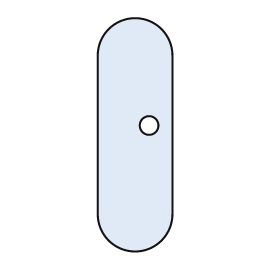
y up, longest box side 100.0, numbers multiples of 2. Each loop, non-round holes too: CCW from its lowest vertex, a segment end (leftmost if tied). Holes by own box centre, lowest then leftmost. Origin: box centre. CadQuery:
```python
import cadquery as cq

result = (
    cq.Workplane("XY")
    .moveTo(-16.0, -34.0)
    .threePointArc((0.0, -50.0), (16.0, -34.0))
    .lineTo(16.0, 34.0)
    .threePointArc((0.0, 50.0), (-16.0, 34.0))
    .close()
    .moveTo(6.0, 4.0)
    .circle(4.0)
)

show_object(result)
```